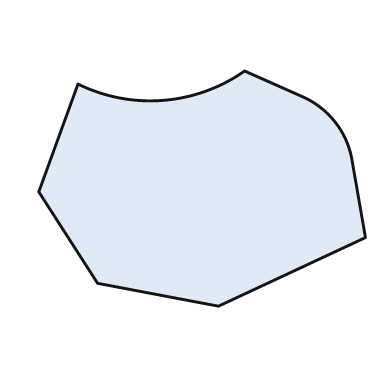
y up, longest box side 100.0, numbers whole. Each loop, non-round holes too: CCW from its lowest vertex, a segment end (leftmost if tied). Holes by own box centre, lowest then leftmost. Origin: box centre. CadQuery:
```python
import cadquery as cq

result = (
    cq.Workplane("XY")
    .moveTo(5.0, -36.0)
    .lineTo(50.0, -15.0)
    .lineTo(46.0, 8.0)
    .threePointArc((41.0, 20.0), (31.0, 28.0))
    .lineTo(13.0, 36.0)
    .threePointArc((-12.0, 27.0), (-38.0, 32.0))
    .lineTo(-50.0, -1.0)
    .lineTo(-32.0, -29.0)
    .close()
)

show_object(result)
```